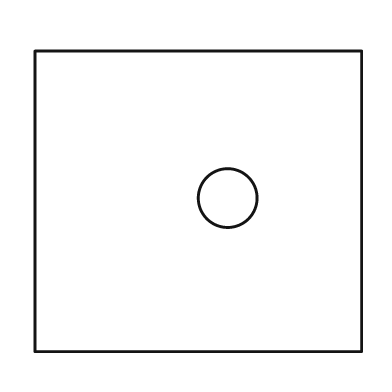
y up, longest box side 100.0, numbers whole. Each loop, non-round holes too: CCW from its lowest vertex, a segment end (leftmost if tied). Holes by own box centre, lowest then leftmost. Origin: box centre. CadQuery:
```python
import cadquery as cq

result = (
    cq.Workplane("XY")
    .moveTo(-50.0, -46.0)
    .lineTo(50.0, -46.0)
    .lineTo(50.0, 46.0)
    .lineTo(-50.0, 46.0)
    .close()
    .moveTo(9.0, 1.0)
    .circle(9.0)
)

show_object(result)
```